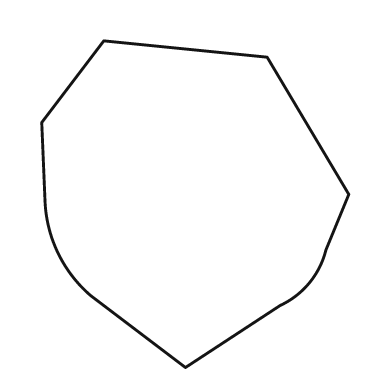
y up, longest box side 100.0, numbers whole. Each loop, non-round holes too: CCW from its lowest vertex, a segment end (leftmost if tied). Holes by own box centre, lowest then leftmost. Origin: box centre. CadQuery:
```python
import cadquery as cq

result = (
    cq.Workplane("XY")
    .moveTo(-3.0, -50.0)
    .lineTo(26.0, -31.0)
    .threePointArc((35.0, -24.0), (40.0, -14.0))
    .lineTo(47.0, 3.0)
    .lineTo(22.0, 45.0)
    .lineTo(-28.0, 50.0)
    .lineTo(-47.0, 25.0)
    .lineTo(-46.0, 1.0)
    .threePointArc((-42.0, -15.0), (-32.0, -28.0))
    .close()
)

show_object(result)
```